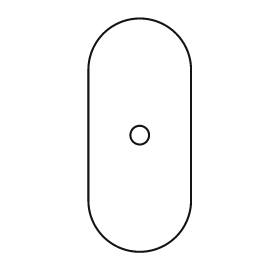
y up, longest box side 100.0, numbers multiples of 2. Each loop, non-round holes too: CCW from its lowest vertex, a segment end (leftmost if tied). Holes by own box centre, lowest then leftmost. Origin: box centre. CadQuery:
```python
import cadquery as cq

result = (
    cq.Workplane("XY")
    .moveTo(-22.0, -28.0)
    .threePointArc((0.0, -50.0), (22.0, -28.0))
    .lineTo(22.0, 28.0)
    .threePointArc((0.0, 50.0), (-22.0, 28.0))
    .close()
    .moveTo(0.0, 0.0)
    .circle(4.0)
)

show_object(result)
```